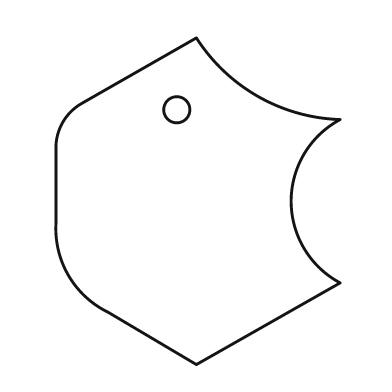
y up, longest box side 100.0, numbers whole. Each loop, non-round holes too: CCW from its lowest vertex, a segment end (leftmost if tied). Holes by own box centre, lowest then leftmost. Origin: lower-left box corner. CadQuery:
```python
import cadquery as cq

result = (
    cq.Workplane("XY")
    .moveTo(43.0, 0.0)
    .lineTo(87.0, 25.0)
    .threePointArc((72.0, 50.0), (87.0, 75.0))
    .threePointArc((62.0, 82.0), (43.0, 100.0))
    .lineTo(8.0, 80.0)
    .threePointArc((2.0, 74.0), (0.0, 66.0))
    .lineTo(0.0, 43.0)
    .threePointArc((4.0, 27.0), (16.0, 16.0))
    .close()
    .moveTo(37.0, 78.0)
    .circle(4.0)
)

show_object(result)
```